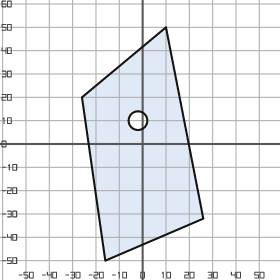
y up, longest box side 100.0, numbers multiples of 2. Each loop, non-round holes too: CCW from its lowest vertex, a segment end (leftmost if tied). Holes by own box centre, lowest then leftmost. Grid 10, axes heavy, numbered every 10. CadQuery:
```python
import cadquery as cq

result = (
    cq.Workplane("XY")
    .moveTo(-16.0, -50.0)
    .lineTo(26.0, -32.0)
    .lineTo(10.0, 50.0)
    .lineTo(-26.0, 20.0)
    .close()
    .moveTo(-2.0, 10.0)
    .circle(4.0)
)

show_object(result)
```